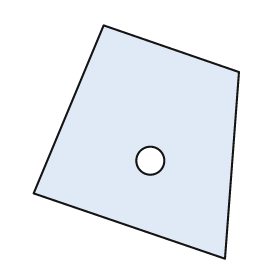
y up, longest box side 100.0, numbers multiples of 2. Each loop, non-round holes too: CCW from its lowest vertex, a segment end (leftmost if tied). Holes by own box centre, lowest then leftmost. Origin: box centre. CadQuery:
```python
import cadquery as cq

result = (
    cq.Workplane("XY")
    .moveTo(38.0, -50.0)
    .lineTo(44.0, 30.0)
    .lineTo(-14.0, 50.0)
    .lineTo(-44.0, -22.0)
    .close()
    .moveTo(6.0, -8.0)
    .circle(6.0)
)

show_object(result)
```